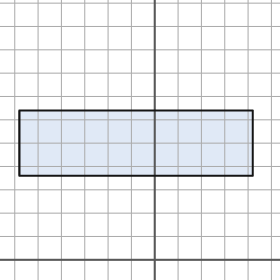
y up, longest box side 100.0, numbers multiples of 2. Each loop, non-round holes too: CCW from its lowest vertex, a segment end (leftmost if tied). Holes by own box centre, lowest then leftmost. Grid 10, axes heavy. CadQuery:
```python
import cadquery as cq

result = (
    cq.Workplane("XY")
    .moveTo(-58.0, 36.0)
    .lineTo(42.0, 36.0)
    .lineTo(42.0, 64.0)
    .lineTo(-58.0, 64.0)
    .close()
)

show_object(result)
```